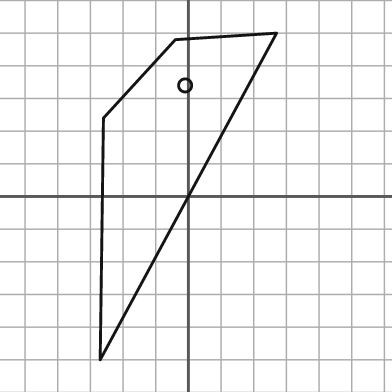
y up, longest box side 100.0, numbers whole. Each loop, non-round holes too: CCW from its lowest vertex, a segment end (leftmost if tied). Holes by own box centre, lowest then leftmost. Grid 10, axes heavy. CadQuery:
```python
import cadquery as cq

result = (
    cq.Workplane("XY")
    .moveTo(-27.0, -50.0)
    .lineTo(27.0, 50.0)
    .lineTo(-4.0, 48.0)
    .lineTo(-26.0, 24.0)
    .close()
    .moveTo(-1.0, 34.0)
    .circle(2.0)
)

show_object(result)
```